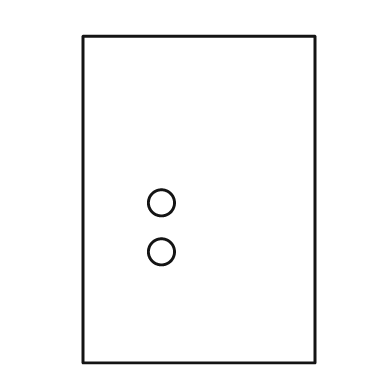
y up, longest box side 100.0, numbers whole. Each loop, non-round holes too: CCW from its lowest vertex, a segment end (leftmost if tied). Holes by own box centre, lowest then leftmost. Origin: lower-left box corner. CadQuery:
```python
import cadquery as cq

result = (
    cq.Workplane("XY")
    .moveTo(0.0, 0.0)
    .lineTo(71.0, 0.0)
    .lineTo(71.0, 100.0)
    .lineTo(0.0, 100.0)
    .close()
    .moveTo(24.0, 34.0)
    .circle(4.0)
    .moveTo(24.0, 49.0)
    .circle(4.0)
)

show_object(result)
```